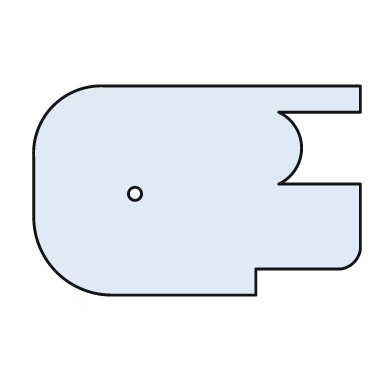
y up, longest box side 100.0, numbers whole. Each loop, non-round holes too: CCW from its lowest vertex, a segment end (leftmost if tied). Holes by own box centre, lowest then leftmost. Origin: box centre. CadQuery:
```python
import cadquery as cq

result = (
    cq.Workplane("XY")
    .moveTo(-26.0, -32.0)
    .lineTo(18.0, -32.0)
    .lineTo(18.0, -24.0)
    .lineTo(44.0, -24.0)
    .threePointArc((48.0, -22.0), (50.0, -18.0))
    .lineTo(50.0, 2.0)
    .lineTo(25.0, 2.0)
    .threePointArc((32.0, 13.0), (25.0, 24.0))
    .lineTo(50.0, 24.0)
    .lineTo(50.0, 32.0)
    .lineTo(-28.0, 32.0)
    .threePointArc((-44.0, 26.0), (-50.0, 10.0))
    .lineTo(-50.0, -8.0)
    .threePointArc((-43.0, -25.0), (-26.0, -32.0))
    .close()
    .moveTo(-19.0, -1.0)
    .circle(2.0)
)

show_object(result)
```